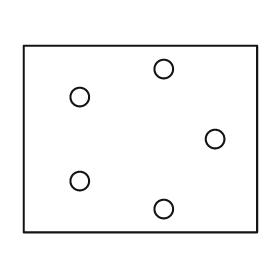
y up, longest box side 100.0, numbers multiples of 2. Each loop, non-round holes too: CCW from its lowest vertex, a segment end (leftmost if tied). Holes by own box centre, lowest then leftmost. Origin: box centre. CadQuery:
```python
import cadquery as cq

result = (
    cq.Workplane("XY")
    .moveTo(-50.0, -40.0)
    .lineTo(50.0, -40.0)
    .lineTo(50.0, 40.0)
    .lineTo(-50.0, 40.0)
    .close()
    .moveTo(10.0, -30.0)
    .circle(4.0)
    .moveTo(-26.0, -18.0)
    .circle(4.0)
    .moveTo(32.0, 0.0)
    .circle(4.0)
    .moveTo(-26.0, 18.0)
    .circle(4.0)
    .moveTo(10.0, 30.0)
    .circle(4.0)
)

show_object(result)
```